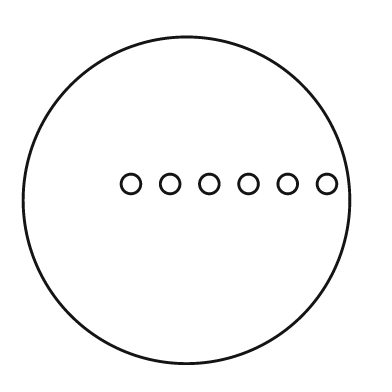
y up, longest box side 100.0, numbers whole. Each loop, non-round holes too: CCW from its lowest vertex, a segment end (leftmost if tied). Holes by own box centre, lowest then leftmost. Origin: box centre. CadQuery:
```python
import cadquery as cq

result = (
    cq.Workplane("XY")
    .moveTo(0.0, 0.0)
    .circle(50.0)
    .moveTo(-17.0, 5.0)
    .circle(3.0)
    .moveTo(-5.0, 5.0)
    .circle(3.0)
    .moveTo(7.0, 5.0)
    .circle(3.0)
    .moveTo(19.0, 5.0)
    .circle(3.0)
    .moveTo(31.0, 5.0)
    .circle(3.0)
    .moveTo(43.0, 5.0)
    .circle(3.0)
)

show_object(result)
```